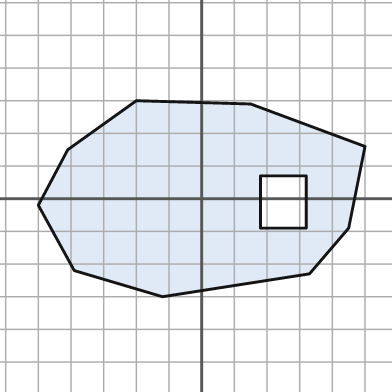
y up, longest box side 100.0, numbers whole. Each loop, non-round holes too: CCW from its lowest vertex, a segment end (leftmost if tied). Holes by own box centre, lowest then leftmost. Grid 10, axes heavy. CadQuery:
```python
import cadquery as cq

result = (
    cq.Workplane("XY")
    .moveTo(-12.0, -30.0)
    .lineTo(33.0, -23.0)
    .lineTo(45.0, -9.0)
    .lineTo(50.0, 16.0)
    .lineTo(15.0, 29.0)
    .lineTo(-20.0, 30.0)
    .lineTo(-41.0, 15.0)
    .lineTo(-50.0, -2.0)
    .lineTo(-39.0, -22.0)
    .close()
    .moveTo(18.0, -9.0)
    .lineTo(32.0, -9.0)
    .lineTo(32.0, 7.0)
    .lineTo(18.0, 7.0)
    .close()
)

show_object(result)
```